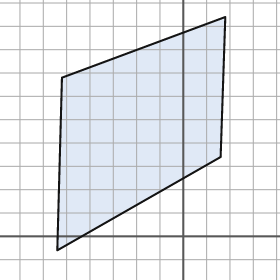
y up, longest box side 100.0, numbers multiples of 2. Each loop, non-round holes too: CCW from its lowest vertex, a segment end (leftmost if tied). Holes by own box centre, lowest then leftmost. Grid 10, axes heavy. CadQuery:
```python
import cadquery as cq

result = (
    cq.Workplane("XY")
    .moveTo(-54.0, -6.0)
    .lineTo(16.0, 34.0)
    .lineTo(18.0, 94.0)
    .lineTo(-52.0, 68.0)
    .close()
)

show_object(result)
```